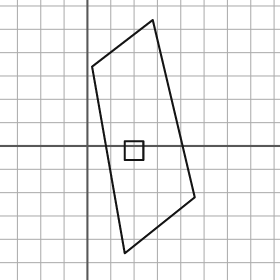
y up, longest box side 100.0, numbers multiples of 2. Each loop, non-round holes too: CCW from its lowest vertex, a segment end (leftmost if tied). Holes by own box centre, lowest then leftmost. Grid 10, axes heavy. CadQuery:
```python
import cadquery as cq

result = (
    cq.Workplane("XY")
    .moveTo(16.0, -46.0)
    .lineTo(46.0, -22.0)
    .lineTo(28.0, 54.0)
    .lineTo(2.0, 34.0)
    .close()
    .moveTo(16.0, -6.0)
    .lineTo(24.0, -6.0)
    .lineTo(24.0, 2.0)
    .lineTo(16.0, 2.0)
    .close()
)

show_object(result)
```